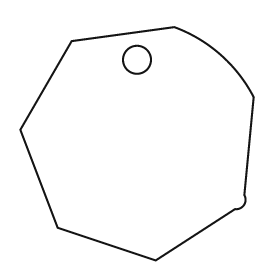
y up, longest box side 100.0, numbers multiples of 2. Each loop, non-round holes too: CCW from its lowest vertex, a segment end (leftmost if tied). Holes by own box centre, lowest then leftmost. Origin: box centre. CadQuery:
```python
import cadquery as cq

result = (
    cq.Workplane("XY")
    .moveTo(8.0, -50.0)
    .lineTo(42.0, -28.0)
    .threePointArc((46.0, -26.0), (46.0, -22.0))
    .lineTo(50.0, 20.0)
    .threePointArc((36.0, 38.0), (16.0, 50.0))
    .lineTo(-28.0, 44.0)
    .lineTo(-50.0, 6.0)
    .lineTo(-34.0, -36.0)
    .close()
    .moveTo(0.0, 36.0)
    .circle(6.0)
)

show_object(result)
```